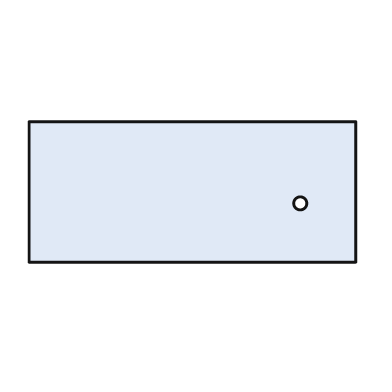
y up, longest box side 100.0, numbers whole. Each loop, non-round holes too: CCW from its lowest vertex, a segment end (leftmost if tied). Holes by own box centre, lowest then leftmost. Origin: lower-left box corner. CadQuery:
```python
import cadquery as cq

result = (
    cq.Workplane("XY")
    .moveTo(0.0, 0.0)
    .lineTo(100.0, 0.0)
    .lineTo(100.0, 43.0)
    .lineTo(0.0, 43.0)
    .close()
    .moveTo(83.0, 18.0)
    .circle(2.0)
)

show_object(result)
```